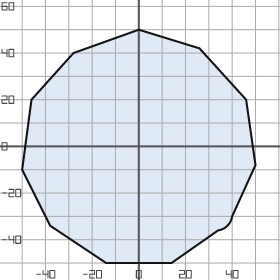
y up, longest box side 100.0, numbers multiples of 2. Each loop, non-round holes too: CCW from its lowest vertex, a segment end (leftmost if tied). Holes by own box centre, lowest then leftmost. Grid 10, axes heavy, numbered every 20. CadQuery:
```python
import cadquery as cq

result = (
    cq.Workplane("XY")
    .moveTo(-14.0, -50.0)
    .lineTo(14.0, -50.0)
    .lineTo(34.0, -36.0)
    .threePointArc((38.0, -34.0), (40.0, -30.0))
    .lineTo(50.0, -8.0)
    .lineTo(46.0, 20.0)
    .lineTo(26.0, 42.0)
    .lineTo(0.0, 50.0)
    .lineTo(-28.0, 40.0)
    .lineTo(-46.0, 20.0)
    .lineTo(-50.0, -10.0)
    .lineTo(-38.0, -34.0)
    .close()
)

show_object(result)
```